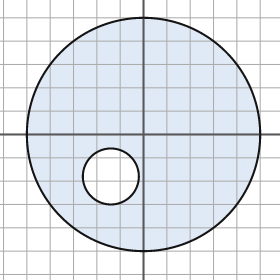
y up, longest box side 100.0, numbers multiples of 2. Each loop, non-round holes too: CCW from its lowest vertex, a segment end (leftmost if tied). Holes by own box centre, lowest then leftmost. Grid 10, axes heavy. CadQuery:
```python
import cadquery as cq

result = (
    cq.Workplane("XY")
    .moveTo(0.0, 0.0)
    .circle(50.0)
    .moveTo(-14.0, -18.0)
    .circle(12.0)
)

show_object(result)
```